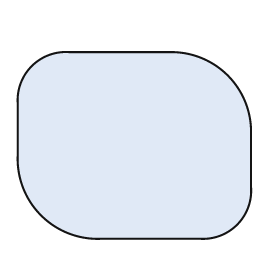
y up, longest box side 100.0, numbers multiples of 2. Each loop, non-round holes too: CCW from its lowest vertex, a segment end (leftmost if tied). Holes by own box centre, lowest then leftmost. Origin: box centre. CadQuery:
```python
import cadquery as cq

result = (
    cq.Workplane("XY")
    .moveTo(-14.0, -40.0)
    .lineTo(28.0, -40.0)
    .threePointArc((44.0, -34.0), (50.0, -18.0))
    .lineTo(50.0, 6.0)
    .threePointArc((40.0, 30.0), (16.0, 40.0))
    .lineTo(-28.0, 40.0)
    .threePointArc((-44.0, 34.0), (-50.0, 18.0))
    .lineTo(-50.0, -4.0)
    .threePointArc((-40.0, -30.0), (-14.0, -40.0))
    .close()
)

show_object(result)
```